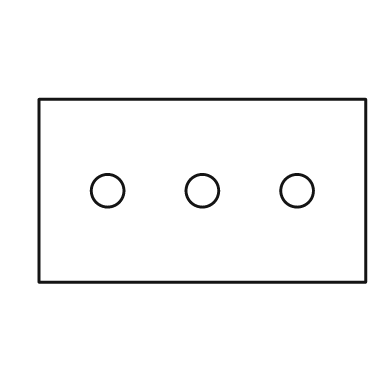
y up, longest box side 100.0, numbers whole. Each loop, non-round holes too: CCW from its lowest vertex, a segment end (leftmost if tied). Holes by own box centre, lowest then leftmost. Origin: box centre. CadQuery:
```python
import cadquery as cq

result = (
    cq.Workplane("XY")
    .moveTo(-50.0, -28.0)
    .lineTo(50.0, -28.0)
    .lineTo(50.0, 28.0)
    .lineTo(-50.0, 28.0)
    .close()
    .moveTo(-29.0, 0.0)
    .circle(5.0)
    .moveTo(0.0, 0.0)
    .circle(5.0)
    .moveTo(29.0, 0.0)
    .circle(5.0)
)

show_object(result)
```